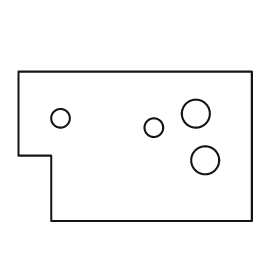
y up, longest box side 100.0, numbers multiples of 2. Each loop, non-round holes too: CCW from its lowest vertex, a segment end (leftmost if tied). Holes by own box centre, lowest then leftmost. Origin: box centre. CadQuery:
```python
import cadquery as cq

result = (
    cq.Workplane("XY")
    .moveTo(-36.0, -32.0)
    .lineTo(50.0, -32.0)
    .lineTo(50.0, 32.0)
    .lineTo(-50.0, 32.0)
    .lineTo(-50.0, -4.0)
    .lineTo(-36.0, -4.0)
    .close()
    .moveTo(30.0, -6.0)
    .circle(6.0)
    .moveTo(8.0, 8.0)
    .circle(4.0)
    .moveTo(-32.0, 12.0)
    .circle(4.0)
    .moveTo(26.0, 14.0)
    .circle(6.0)
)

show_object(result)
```